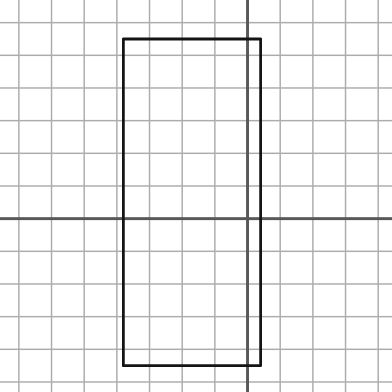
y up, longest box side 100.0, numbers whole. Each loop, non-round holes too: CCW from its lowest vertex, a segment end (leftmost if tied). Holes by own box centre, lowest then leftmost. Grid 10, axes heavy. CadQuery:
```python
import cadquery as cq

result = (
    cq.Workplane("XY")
    .moveTo(-38.0, -45.0)
    .lineTo(4.0, -45.0)
    .lineTo(4.0, 55.0)
    .lineTo(-38.0, 55.0)
    .close()
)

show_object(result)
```